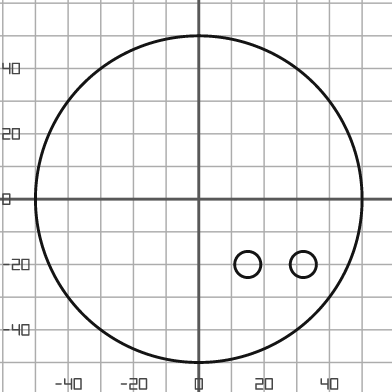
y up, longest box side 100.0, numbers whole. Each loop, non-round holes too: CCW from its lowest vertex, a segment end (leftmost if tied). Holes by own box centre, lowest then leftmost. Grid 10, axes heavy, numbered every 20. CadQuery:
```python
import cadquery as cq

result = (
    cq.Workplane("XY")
    .moveTo(0.0, 0.0)
    .circle(50.0)
    .moveTo(15.0, -20.0)
    .circle(4.0)
    .moveTo(32.0, -20.0)
    .circle(4.0)
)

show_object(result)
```